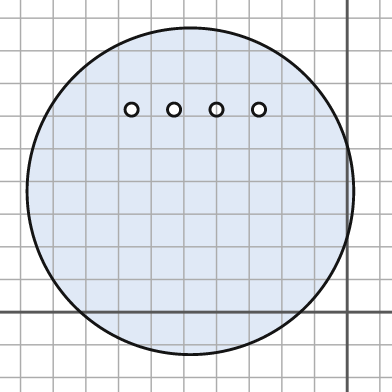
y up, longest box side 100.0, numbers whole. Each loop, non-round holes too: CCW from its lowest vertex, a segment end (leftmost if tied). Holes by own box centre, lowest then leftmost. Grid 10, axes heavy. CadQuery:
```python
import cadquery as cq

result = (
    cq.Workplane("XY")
    .moveTo(-48.0, 37.0)
    .circle(50.0)
    .moveTo(-66.0, 62.0)
    .circle(2.0)
    .moveTo(-53.0, 62.0)
    .circle(2.0)
    .moveTo(-40.0, 62.0)
    .circle(2.0)
    .moveTo(-27.0, 62.0)
    .circle(2.0)
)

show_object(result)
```